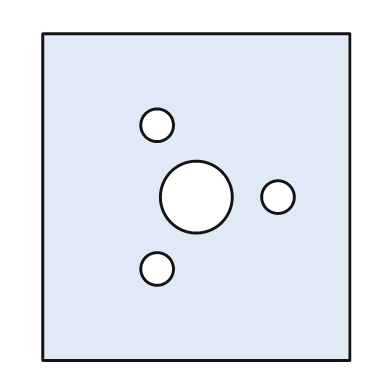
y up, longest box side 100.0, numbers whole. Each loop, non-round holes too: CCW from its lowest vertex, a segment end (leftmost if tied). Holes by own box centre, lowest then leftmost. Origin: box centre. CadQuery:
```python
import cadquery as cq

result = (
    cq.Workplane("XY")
    .moveTo(-47.0, -50.0)
    .lineTo(47.0, -50.0)
    .lineTo(47.0, 50.0)
    .lineTo(-47.0, 50.0)
    .close()
    .moveTo(-12.0, -22.0)
    .circle(5.0)
    .moveTo(0.0, 0.0)
    .circle(11.0)
    .moveTo(25.0, 0.0)
    .circle(5.0)
    .moveTo(-12.0, 22.0)
    .circle(5.0)
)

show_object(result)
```